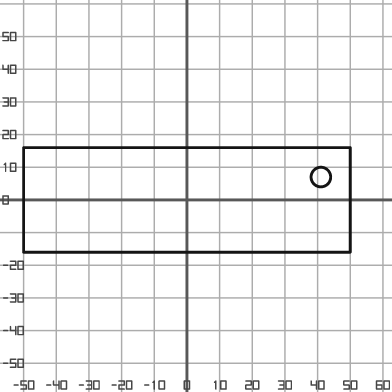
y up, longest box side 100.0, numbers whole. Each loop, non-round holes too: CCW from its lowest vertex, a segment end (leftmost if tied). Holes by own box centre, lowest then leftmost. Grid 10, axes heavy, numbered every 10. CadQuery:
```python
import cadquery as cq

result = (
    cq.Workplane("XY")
    .moveTo(-50.0, -16.0)
    .lineTo(50.0, -16.0)
    .lineTo(50.0, 16.0)
    .lineTo(-50.0, 16.0)
    .close()
    .moveTo(41.0, 7.0)
    .circle(3.0)
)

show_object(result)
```